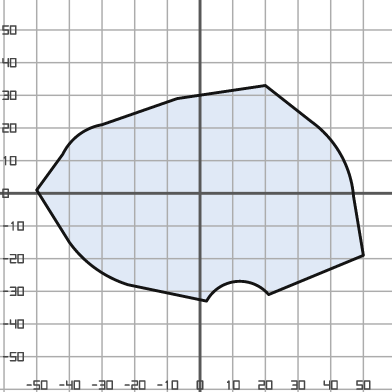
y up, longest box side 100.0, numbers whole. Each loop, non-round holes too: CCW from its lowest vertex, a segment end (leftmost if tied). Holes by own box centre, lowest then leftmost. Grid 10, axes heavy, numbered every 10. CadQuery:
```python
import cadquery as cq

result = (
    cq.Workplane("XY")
    .moveTo(2.0, -33.0)
    .threePointArc((11.0, -27.0), (21.0, -31.0))
    .lineTo(50.0, -19.0)
    .lineTo(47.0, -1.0)
    .threePointArc((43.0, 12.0), (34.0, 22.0))
    .lineTo(20.0, 33.0)
    .lineTo(-7.0, 29.0)
    .lineTo(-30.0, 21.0)
    .threePointArc((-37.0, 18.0), (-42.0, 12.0))
    .lineTo(-50.0, 1.0)
    .lineTo(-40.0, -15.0)
    .threePointArc((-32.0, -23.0), (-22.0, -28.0))
    .close()
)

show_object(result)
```